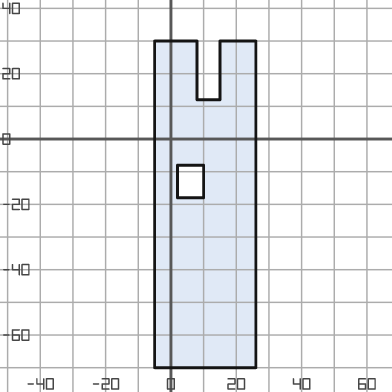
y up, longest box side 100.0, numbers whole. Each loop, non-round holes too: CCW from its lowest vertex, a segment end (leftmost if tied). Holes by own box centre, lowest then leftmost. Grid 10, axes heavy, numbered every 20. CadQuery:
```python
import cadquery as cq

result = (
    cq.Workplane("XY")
    .moveTo(-5.0, -70.0)
    .lineTo(26.0, -70.0)
    .lineTo(26.0, 30.0)
    .lineTo(15.0, 30.0)
    .lineTo(15.0, 12.0)
    .lineTo(8.0, 12.0)
    .lineTo(8.0, 30.0)
    .lineTo(-5.0, 30.0)
    .close()
    .moveTo(2.0, -18.0)
    .lineTo(10.0, -18.0)
    .lineTo(10.0, -8.0)
    .lineTo(2.0, -8.0)
    .close()
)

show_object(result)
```